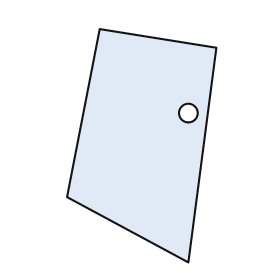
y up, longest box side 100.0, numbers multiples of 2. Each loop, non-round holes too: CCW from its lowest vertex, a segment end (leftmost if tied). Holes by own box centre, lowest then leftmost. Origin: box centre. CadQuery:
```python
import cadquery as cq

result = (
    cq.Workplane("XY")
    .moveTo(20.0, -50.0)
    .lineTo(32.0, 42.0)
    .lineTo(-18.0, 50.0)
    .lineTo(-32.0, -22.0)
    .close()
    .moveTo(20.0, 14.0)
    .circle(4.0)
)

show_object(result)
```